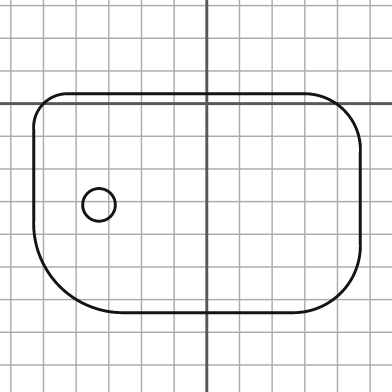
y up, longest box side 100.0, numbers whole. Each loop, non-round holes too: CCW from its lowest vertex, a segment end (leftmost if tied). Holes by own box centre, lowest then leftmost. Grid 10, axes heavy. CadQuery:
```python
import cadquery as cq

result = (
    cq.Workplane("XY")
    .moveTo(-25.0, -64.0)
    .lineTo(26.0, -64.0)
    .threePointArc((41.0, -58.0), (47.0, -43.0))
    .lineTo(47.0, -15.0)
    .threePointArc((42.0, -2.0), (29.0, 3.0))
    .lineTo(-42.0, 3.0)
    .threePointArc((-50.0, 0.0), (-53.0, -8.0))
    .lineTo(-53.0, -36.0)
    .threePointArc((-45.0, -56.0), (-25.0, -64.0))
    .close()
    .moveTo(-33.0, -31.0)
    .circle(5.0)
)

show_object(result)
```